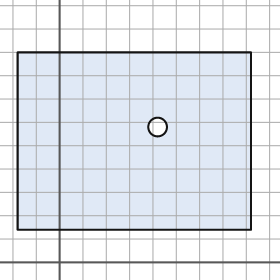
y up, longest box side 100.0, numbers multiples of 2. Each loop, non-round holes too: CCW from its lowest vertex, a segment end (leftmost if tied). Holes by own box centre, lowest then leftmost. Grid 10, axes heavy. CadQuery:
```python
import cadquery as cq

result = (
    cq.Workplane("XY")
    .moveTo(-18.0, 14.0)
    .lineTo(82.0, 14.0)
    .lineTo(82.0, 90.0)
    .lineTo(-18.0, 90.0)
    .close()
    .moveTo(42.0, 58.0)
    .circle(4.0)
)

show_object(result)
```